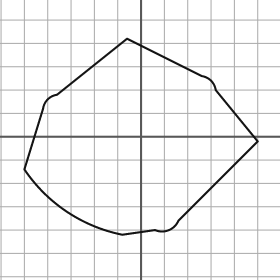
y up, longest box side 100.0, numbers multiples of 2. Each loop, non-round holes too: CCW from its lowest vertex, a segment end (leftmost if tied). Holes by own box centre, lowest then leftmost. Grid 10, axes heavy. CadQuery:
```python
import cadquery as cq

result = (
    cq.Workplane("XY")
    .moveTo(-8.0, -42.0)
    .lineTo(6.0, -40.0)
    .threePointArc((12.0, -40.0), (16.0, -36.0))
    .lineTo(50.0, -2.0)
    .lineTo(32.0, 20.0)
    .threePointArc((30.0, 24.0), (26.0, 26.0))
    .lineTo(-6.0, 42.0)
    .lineTo(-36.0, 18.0)
    .threePointArc((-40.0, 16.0), (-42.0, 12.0))
    .lineTo(-50.0, -14.0)
    .threePointArc((-32.0, -32.0), (-8.0, -42.0))
    .close()
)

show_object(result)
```